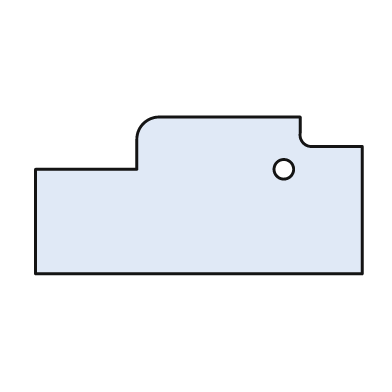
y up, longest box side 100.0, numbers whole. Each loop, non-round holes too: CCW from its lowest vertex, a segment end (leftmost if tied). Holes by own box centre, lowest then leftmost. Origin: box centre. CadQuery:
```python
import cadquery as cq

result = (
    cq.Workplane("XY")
    .moveTo(-50.0, -24.0)
    .lineTo(50.0, -24.0)
    .lineTo(50.0, 15.0)
    .lineTo(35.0, 15.0)
    .threePointArc((32.0, 16.0), (31.0, 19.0))
    .lineTo(31.0, 24.0)
    .lineTo(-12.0, 24.0)
    .threePointArc((-17.0, 22.0), (-19.0, 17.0))
    .lineTo(-19.0, 8.0)
    .lineTo(-50.0, 8.0)
    .close()
    .moveTo(26.0, 8.0)
    .circle(3.0)
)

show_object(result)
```